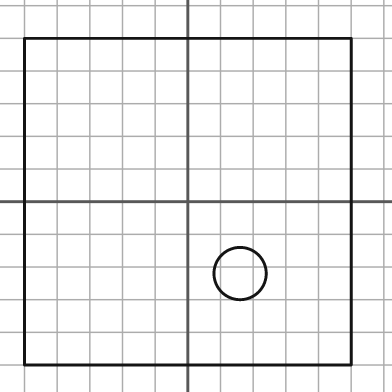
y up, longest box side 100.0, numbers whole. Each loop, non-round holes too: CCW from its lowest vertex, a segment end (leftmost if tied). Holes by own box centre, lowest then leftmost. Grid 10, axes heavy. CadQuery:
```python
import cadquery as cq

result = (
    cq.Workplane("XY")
    .moveTo(-50.0, -50.0)
    .lineTo(50.0, -50.0)
    .lineTo(50.0, 50.0)
    .lineTo(-50.0, 50.0)
    .close()
    .moveTo(16.0, -22.0)
    .circle(8.0)
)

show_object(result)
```